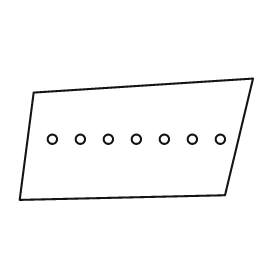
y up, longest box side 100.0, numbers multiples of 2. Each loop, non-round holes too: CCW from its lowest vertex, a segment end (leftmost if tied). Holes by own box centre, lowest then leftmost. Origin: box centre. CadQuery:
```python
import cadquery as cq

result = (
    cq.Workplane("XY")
    .moveTo(-50.0, -26.0)
    .lineTo(38.0, -24.0)
    .lineTo(50.0, 26.0)
    .lineTo(-44.0, 20.0)
    .close()
    .moveTo(-36.0, 0.0)
    .circle(2.0)
    .moveTo(-24.0, 0.0)
    .circle(2.0)
    .moveTo(-12.0, 0.0)
    .circle(2.0)
    .moveTo(0.0, 0.0)
    .circle(2.0)
    .moveTo(12.0, 0.0)
    .circle(2.0)
    .moveTo(24.0, 0.0)
    .circle(2.0)
    .moveTo(36.0, 0.0)
    .circle(2.0)
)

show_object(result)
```